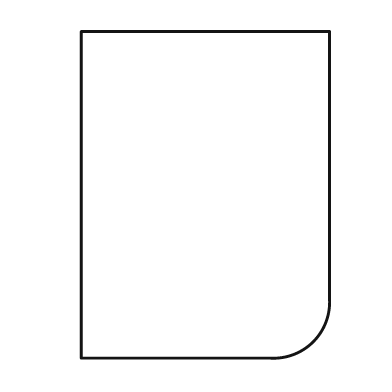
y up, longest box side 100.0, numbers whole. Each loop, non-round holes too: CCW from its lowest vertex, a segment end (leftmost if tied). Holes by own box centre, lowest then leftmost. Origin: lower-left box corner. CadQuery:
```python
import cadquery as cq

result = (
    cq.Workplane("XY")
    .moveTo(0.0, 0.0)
    .lineTo(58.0, 0.0)
    .threePointArc((71.0, 5.0), (76.0, 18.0))
    .lineTo(76.0, 100.0)
    .lineTo(0.0, 100.0)
    .close()
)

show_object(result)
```